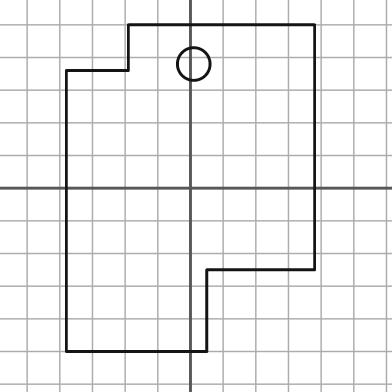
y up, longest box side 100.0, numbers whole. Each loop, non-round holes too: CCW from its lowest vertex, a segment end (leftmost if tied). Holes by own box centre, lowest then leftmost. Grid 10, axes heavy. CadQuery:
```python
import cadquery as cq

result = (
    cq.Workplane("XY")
    .moveTo(-38.0, -50.0)
    .lineTo(5.0, -50.0)
    .lineTo(5.0, -25.0)
    .lineTo(38.0, -25.0)
    .lineTo(38.0, 50.0)
    .lineTo(-19.0, 50.0)
    .lineTo(-19.0, 36.0)
    .lineTo(-38.0, 36.0)
    .close()
    .moveTo(1.0, 38.0)
    .circle(5.0)
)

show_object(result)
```